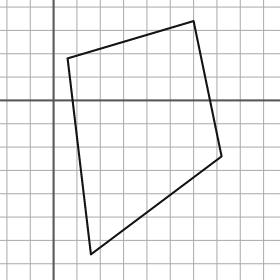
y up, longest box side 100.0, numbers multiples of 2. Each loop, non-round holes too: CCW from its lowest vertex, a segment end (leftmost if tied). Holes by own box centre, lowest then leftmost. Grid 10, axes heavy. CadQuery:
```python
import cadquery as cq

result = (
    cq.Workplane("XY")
    .moveTo(16.0, -66.0)
    .lineTo(72.0, -24.0)
    .lineTo(60.0, 34.0)
    .lineTo(6.0, 18.0)
    .close()
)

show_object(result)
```